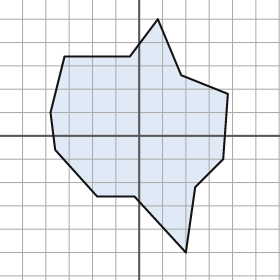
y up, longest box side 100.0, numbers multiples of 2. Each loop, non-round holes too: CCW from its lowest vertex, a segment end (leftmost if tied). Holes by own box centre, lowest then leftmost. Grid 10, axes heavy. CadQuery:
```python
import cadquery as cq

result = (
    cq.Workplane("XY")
    .moveTo(20.0, -50.0)
    .lineTo(24.0, -22.0)
    .lineTo(36.0, -10.0)
    .lineTo(38.0, 18.0)
    .lineTo(18.0, 26.0)
    .lineTo(8.0, 50.0)
    .lineTo(-4.0, 34.0)
    .lineTo(-32.0, 34.0)
    .lineTo(-38.0, 10.0)
    .lineTo(-36.0, -6.0)
    .lineTo(-18.0, -26.0)
    .lineTo(-2.0, -26.0)
    .close()
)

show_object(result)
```